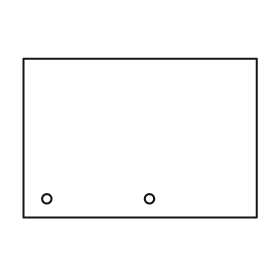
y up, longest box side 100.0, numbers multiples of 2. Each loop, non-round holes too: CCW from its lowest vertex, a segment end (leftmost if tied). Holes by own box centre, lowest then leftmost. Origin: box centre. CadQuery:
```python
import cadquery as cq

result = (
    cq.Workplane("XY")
    .moveTo(-50.0, -34.0)
    .lineTo(50.0, -34.0)
    .lineTo(50.0, 34.0)
    .lineTo(-50.0, 34.0)
    .close()
    .moveTo(-40.0, -26.0)
    .circle(2.0)
    .moveTo(4.0, -26.0)
    .circle(2.0)
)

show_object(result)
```